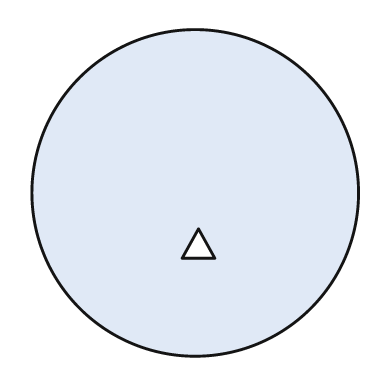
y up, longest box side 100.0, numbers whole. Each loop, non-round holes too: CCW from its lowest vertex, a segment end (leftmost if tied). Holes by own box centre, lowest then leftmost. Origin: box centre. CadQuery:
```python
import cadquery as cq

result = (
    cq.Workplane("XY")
    .moveTo(0.0, 0.0)
    .circle(50.0)
    .moveTo(-4.0, -20.0)
    .lineTo(6.0, -20.0)
    .lineTo(1.0, -11.0)
    .close()
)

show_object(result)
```